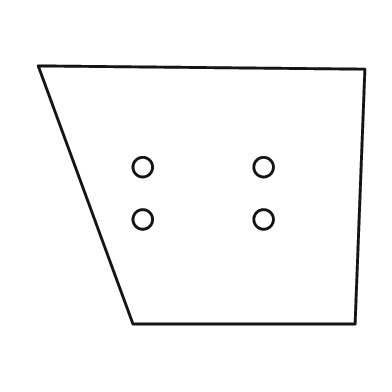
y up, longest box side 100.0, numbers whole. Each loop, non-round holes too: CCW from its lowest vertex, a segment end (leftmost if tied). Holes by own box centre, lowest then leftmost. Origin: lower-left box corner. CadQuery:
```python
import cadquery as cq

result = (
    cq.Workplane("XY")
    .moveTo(29.0, 0.0)
    .lineTo(97.0, 0.0)
    .lineTo(100.0, 78.0)
    .lineTo(0.0, 79.0)
    .close()
    .moveTo(32.0, 32.0)
    .circle(3.0)
    .moveTo(69.0, 32.0)
    .circle(3.0)
    .moveTo(32.0, 48.0)
    .circle(3.0)
    .moveTo(69.0, 48.0)
    .circle(3.0)
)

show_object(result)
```